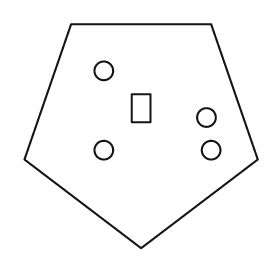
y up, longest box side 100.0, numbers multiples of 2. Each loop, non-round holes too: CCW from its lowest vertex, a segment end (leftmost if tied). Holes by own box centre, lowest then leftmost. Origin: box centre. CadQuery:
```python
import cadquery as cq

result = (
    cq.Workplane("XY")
    .moveTo(0.0, -48.0)
    .lineTo(50.0, -10.0)
    .lineTo(30.0, 48.0)
    .lineTo(-30.0, 48.0)
    .lineTo(-50.0, -10.0)
    .close()
    .moveTo(-16.0, -6.0)
    .circle(4.0)
    .moveTo(30.0, -6.0)
    .circle(4.0)
    .moveTo(28.0, 8.0)
    .circle(4.0)
    .moveTo(-4.0, 6.0)
    .lineTo(4.0, 6.0)
    .lineTo(4.0, 18.0)
    .lineTo(-4.0, 18.0)
    .close()
    .moveTo(-16.0, 28.0)
    .circle(4.0)
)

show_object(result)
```